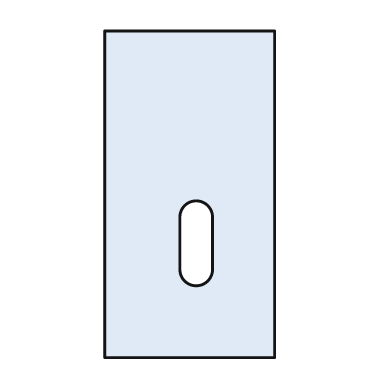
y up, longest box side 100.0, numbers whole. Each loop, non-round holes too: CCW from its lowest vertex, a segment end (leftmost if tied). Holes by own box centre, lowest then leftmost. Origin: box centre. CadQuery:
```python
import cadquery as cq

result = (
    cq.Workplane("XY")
    .moveTo(-26.0, -50.0)
    .lineTo(26.0, -50.0)
    .lineTo(26.0, 50.0)
    .lineTo(-26.0, 50.0)
    .close()
    .moveTo(-3.0, -23.0)
    .threePointArc((2.0, -28.0), (7.0, -23.0))
    .lineTo(7.0, -7.0)
    .threePointArc((2.0, -2.0), (-3.0, -7.0))
    .close()
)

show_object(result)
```